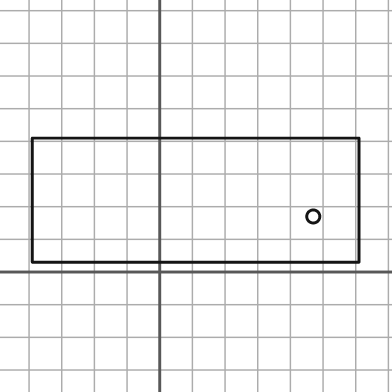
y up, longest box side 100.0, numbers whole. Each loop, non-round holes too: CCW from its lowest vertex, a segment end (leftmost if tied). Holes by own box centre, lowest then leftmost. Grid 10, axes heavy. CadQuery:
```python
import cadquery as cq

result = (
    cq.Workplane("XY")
    .moveTo(-39.0, 3.0)
    .lineTo(61.0, 3.0)
    .lineTo(61.0, 41.0)
    .lineTo(-39.0, 41.0)
    .close()
    .moveTo(47.0, 17.0)
    .circle(2.0)
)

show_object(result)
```